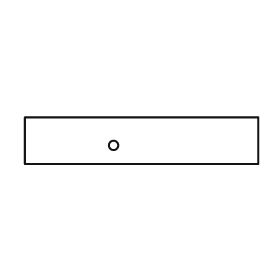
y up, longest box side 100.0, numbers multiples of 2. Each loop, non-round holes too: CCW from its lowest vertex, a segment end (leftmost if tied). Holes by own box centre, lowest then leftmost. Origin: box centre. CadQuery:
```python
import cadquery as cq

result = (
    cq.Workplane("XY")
    .moveTo(-50.0, -10.0)
    .lineTo(50.0, -10.0)
    .lineTo(50.0, 10.0)
    .lineTo(-50.0, 10.0)
    .close()
    .moveTo(-12.0, -2.0)
    .circle(2.0)
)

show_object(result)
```